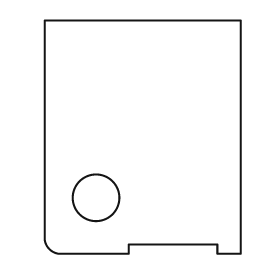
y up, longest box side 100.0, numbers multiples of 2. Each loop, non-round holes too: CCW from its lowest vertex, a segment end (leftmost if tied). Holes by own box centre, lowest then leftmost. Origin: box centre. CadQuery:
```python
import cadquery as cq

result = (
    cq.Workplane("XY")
    .moveTo(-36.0, -50.0)
    .lineTo(-6.0, -50.0)
    .lineTo(-6.0, -46.0)
    .lineTo(32.0, -46.0)
    .lineTo(32.0, -50.0)
    .lineTo(42.0, -50.0)
    .lineTo(42.0, 50.0)
    .lineTo(-42.0, 50.0)
    .lineTo(-42.0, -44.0)
    .threePointArc((-40.0, -48.0), (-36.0, -50.0))
    .close()
    .moveTo(-20.0, -26.0)
    .circle(10.0)
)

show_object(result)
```